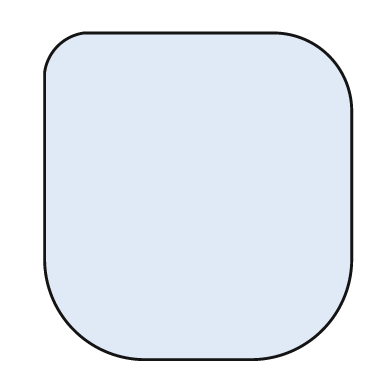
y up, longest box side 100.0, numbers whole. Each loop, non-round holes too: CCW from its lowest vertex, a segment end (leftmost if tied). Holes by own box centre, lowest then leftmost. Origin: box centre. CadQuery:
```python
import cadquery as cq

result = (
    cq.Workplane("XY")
    .moveTo(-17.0, -50.0)
    .lineTo(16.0, -50.0)
    .threePointArc((38.0, -41.0), (47.0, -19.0))
    .lineTo(47.0, 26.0)
    .threePointArc((40.0, 43.0), (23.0, 50.0))
    .lineTo(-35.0, 50.0)
    .threePointArc((-43.0, 46.0), (-47.0, 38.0))
    .lineTo(-47.0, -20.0)
    .threePointArc((-38.0, -41.0), (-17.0, -50.0))
    .close()
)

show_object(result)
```